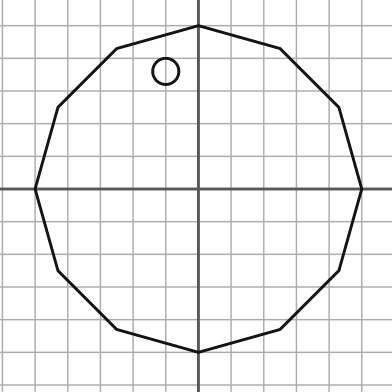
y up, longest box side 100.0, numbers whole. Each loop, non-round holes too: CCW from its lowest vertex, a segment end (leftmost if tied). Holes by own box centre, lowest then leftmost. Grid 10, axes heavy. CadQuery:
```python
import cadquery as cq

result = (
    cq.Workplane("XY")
    .moveTo(0.0, -50.0)
    .lineTo(25.0, -43.0)
    .lineTo(43.0, -25.0)
    .lineTo(50.0, 0.0)
    .lineTo(43.0, 25.0)
    .lineTo(25.0, 43.0)
    .lineTo(0.0, 50.0)
    .lineTo(-25.0, 43.0)
    .lineTo(-43.0, 25.0)
    .lineTo(-50.0, 0.0)
    .lineTo(-43.0, -25.0)
    .lineTo(-25.0, -43.0)
    .close()
    .moveTo(-10.0, 36.0)
    .circle(4.0)
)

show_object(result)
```